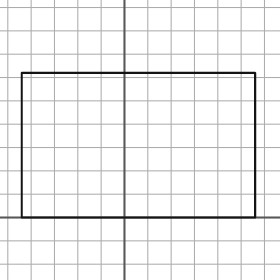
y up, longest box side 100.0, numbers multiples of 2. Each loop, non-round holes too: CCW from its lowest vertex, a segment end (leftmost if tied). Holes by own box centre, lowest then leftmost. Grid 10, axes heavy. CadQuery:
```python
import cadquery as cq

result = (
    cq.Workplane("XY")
    .moveTo(-44.0, 0.0)
    .lineTo(56.0, 0.0)
    .lineTo(56.0, 62.0)
    .lineTo(-44.0, 62.0)
    .close()
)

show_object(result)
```